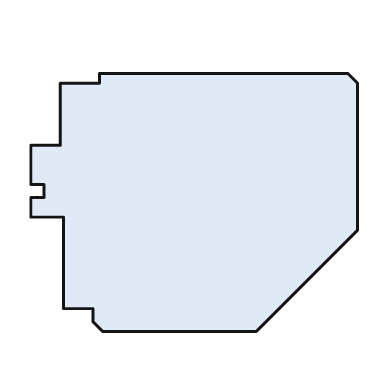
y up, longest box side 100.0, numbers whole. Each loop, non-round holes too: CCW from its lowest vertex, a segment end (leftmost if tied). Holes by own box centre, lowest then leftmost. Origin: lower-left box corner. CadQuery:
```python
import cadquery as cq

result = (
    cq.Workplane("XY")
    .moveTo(22.0, 0.0)
    .lineTo(69.0, 0.0)
    .lineTo(100.0, 31.0)
    .lineTo(100.0, 76.0)
    .lineTo(97.0, 79.0)
    .lineTo(21.0, 79.0)
    .lineTo(21.0, 76.0)
    .lineTo(9.0, 76.0)
    .lineTo(9.0, 57.0)
    .lineTo(0.0, 57.0)
    .lineTo(0.0, 45.0)
    .lineTo(4.0, 45.0)
    .lineTo(4.0, 41.0)
    .lineTo(0.0, 41.0)
    .lineTo(0.0, 35.0)
    .lineTo(10.0, 35.0)
    .lineTo(10.0, 7.0)
    .lineTo(19.0, 7.0)
    .lineTo(19.0, 3.0)
    .close()
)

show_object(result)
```